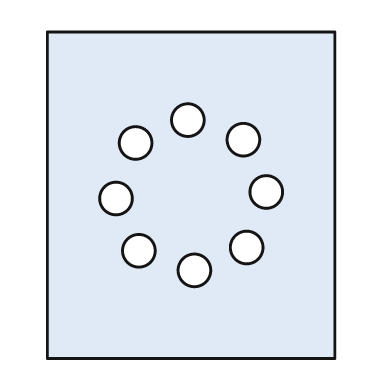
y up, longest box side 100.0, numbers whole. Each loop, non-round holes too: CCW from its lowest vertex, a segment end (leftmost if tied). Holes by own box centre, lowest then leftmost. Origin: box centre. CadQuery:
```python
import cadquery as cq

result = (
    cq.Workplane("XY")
    .moveTo(-44.0, -50.0)
    .lineTo(44.0, -50.0)
    .lineTo(44.0, 50.0)
    .lineTo(-44.0, 50.0)
    .close()
    .moveTo(1.0, -23.0)
    .circle(5.0)
    .moveTo(-16.0, -17.0)
    .circle(5.0)
    .moveTo(17.0, -16.0)
    .circle(5.0)
    .moveTo(-23.0, -1.0)
    .circle(5.0)
    .moveTo(23.0, 1.0)
    .circle(5.0)
    .moveTo(-17.0, 16.0)
    .circle(5.0)
    .moveTo(16.0, 17.0)
    .circle(5.0)
    .moveTo(-1.0, 23.0)
    .circle(5.0)
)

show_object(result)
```